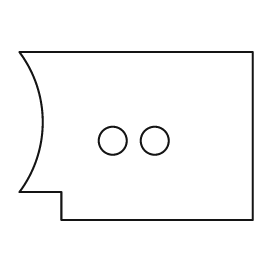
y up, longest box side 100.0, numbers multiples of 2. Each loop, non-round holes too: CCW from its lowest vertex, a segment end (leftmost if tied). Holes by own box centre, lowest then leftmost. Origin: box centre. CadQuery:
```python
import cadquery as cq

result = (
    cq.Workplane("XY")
    .moveTo(-32.0, -36.0)
    .lineTo(50.0, -36.0)
    .lineTo(50.0, 36.0)
    .lineTo(-50.0, 36.0)
    .threePointArc((-40.0, 6.0), (-50.0, -24.0))
    .lineTo(-32.0, -24.0)
    .close()
    .moveTo(-10.0, -2.0)
    .circle(6.0)
    .moveTo(8.0, -2.0)
    .circle(6.0)
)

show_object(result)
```